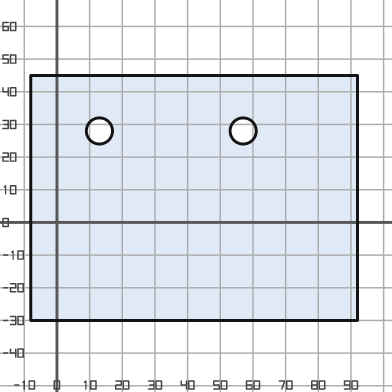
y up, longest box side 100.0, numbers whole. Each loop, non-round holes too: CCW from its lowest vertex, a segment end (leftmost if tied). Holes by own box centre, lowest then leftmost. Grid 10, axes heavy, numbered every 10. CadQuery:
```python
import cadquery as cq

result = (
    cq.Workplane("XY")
    .moveTo(-8.0, -30.0)
    .lineTo(92.0, -30.0)
    .lineTo(92.0, 45.0)
    .lineTo(-8.0, 45.0)
    .close()
    .moveTo(13.0, 28.0)
    .circle(4.0)
    .moveTo(57.0, 28.0)
    .circle(4.0)
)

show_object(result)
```